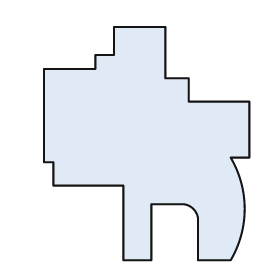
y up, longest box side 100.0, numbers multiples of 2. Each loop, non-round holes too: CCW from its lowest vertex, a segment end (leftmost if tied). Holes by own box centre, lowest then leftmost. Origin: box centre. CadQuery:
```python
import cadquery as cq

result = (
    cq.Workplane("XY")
    .moveTo(-10.0, -50.0)
    .lineTo(2.0, -50.0)
    .lineTo(2.0, -26.0)
    .lineTo(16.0, -26.0)
    .threePointArc((20.0, -28.0), (22.0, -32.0))
    .lineTo(22.0, -50.0)
    .lineTo(36.0, -50.0)
    .threePointArc((42.0, -28.0), (36.0, -6.0))
    .lineTo(44.0, -6.0)
    .lineTo(44.0, 18.0)
    .lineTo(18.0, 18.0)
    .lineTo(18.0, 28.0)
    .lineTo(8.0, 28.0)
    .lineTo(8.0, 50.0)
    .lineTo(-14.0, 50.0)
    .lineTo(-14.0, 38.0)
    .lineTo(-22.0, 38.0)
    .lineTo(-22.0, 32.0)
    .lineTo(-44.0, 32.0)
    .lineTo(-44.0, -8.0)
    .lineTo(-40.0, -8.0)
    .lineTo(-40.0, -18.0)
    .lineTo(-10.0, -18.0)
    .close()
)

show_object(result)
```